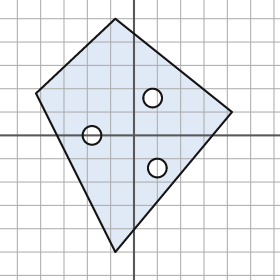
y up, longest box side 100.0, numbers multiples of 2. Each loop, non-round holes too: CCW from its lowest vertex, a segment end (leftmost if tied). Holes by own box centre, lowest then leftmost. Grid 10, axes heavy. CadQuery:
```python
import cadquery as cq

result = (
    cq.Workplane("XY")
    .moveTo(-8.0, -50.0)
    .lineTo(42.0, 10.0)
    .lineTo(-8.0, 50.0)
    .lineTo(-42.0, 18.0)
    .close()
    .moveTo(10.0, -14.0)
    .circle(4.0)
    .moveTo(-18.0, 0.0)
    .circle(4.0)
    .moveTo(8.0, 16.0)
    .circle(4.0)
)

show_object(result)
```